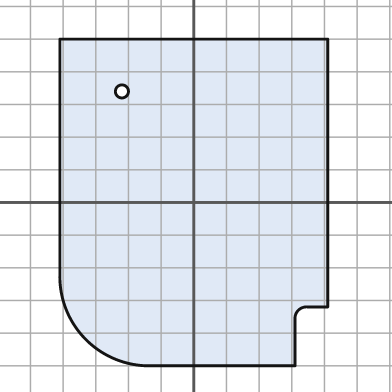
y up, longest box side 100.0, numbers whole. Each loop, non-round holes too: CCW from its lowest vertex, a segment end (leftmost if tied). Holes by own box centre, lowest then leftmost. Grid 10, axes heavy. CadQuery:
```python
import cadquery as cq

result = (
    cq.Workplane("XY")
    .moveTo(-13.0, -50.0)
    .lineTo(31.0, -50.0)
    .lineTo(31.0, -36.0)
    .threePointArc((32.0, -33.0), (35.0, -32.0))
    .lineTo(41.0, -32.0)
    .lineTo(41.0, 50.0)
    .lineTo(-41.0, 50.0)
    .lineTo(-41.0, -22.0)
    .threePointArc((-33.0, -42.0), (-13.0, -50.0))
    .close()
    .moveTo(-22.0, 34.0)
    .circle(2.0)
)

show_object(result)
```